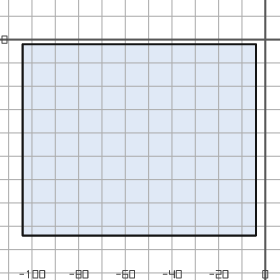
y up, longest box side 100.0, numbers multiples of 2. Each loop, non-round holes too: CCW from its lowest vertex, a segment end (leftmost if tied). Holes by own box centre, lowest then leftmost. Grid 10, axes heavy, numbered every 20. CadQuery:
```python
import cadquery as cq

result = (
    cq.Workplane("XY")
    .moveTo(-104.0, -84.0)
    .lineTo(-4.0, -84.0)
    .lineTo(-4.0, -2.0)
    .lineTo(-104.0, -2.0)
    .close()
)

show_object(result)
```